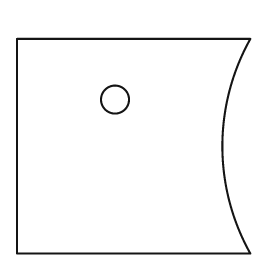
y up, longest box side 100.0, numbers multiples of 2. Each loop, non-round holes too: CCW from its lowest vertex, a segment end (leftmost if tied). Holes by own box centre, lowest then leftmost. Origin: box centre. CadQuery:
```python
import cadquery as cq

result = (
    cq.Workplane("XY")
    .moveTo(-50.0, -46.0)
    .lineTo(50.0, -46.0)
    .threePointArc((38.0, 0.0), (50.0, 46.0))
    .lineTo(-50.0, 46.0)
    .close()
    .moveTo(-8.0, 20.0)
    .circle(6.0)
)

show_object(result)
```